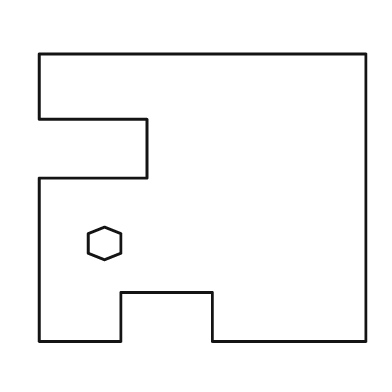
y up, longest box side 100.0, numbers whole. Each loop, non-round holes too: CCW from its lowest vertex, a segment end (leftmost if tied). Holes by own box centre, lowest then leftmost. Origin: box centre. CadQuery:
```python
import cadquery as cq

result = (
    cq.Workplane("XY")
    .moveTo(-50.0, -44.0)
    .lineTo(-25.0, -44.0)
    .lineTo(-25.0, -29.0)
    .lineTo(3.0, -29.0)
    .lineTo(3.0, -44.0)
    .lineTo(50.0, -44.0)
    .lineTo(50.0, 44.0)
    .lineTo(-50.0, 44.0)
    .lineTo(-50.0, 24.0)
    .lineTo(-17.0, 24.0)
    .lineTo(-17.0, 6.0)
    .lineTo(-50.0, 6.0)
    .close()
    .moveTo(-30.0, -19.0)
    .lineTo(-25.0, -17.0)
    .lineTo(-25.0, -11.0)
    .lineTo(-30.0, -9.0)
    .lineTo(-35.0, -11.0)
    .lineTo(-35.0, -17.0)
    .close()
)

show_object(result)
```